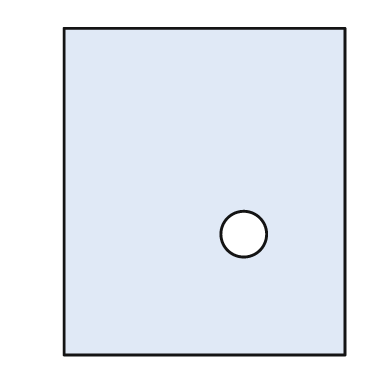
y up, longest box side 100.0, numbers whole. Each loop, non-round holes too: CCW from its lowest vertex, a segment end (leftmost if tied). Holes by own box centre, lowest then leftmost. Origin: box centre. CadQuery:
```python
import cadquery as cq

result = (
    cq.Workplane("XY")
    .moveTo(-43.0, -50.0)
    .lineTo(43.0, -50.0)
    .lineTo(43.0, 50.0)
    .lineTo(-43.0, 50.0)
    .close()
    .moveTo(12.0, -13.0)
    .circle(7.0)
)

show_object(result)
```